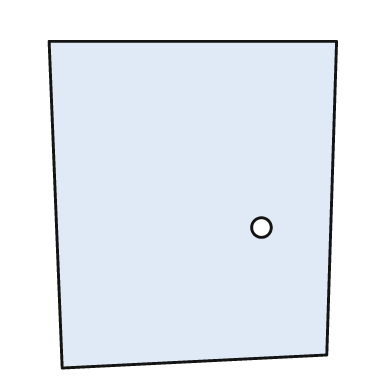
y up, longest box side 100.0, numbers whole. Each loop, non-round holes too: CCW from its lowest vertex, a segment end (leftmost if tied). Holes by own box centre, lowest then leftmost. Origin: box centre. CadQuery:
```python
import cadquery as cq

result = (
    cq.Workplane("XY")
    .moveTo(-40.0, -50.0)
    .lineTo(41.0, -46.0)
    .lineTo(44.0, 50.0)
    .lineTo(-44.0, 50.0)
    .close()
    .moveTo(21.0, -7.0)
    .circle(3.0)
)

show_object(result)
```